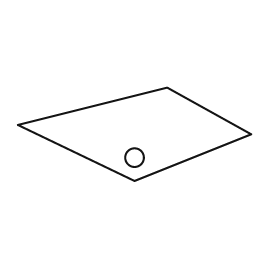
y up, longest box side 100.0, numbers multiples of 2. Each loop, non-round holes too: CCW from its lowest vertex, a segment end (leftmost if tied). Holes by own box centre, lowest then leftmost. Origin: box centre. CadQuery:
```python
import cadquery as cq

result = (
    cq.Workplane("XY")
    .moveTo(0.0, -20.0)
    .lineTo(50.0, 0.0)
    .lineTo(14.0, 20.0)
    .lineTo(-50.0, 4.0)
    .close()
    .moveTo(0.0, -10.0)
    .circle(4.0)
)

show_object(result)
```